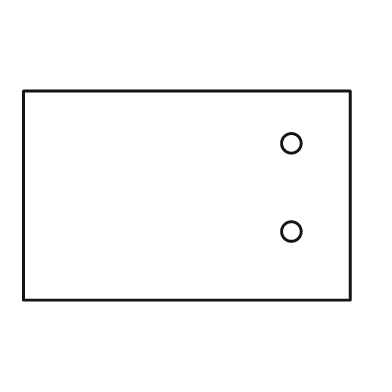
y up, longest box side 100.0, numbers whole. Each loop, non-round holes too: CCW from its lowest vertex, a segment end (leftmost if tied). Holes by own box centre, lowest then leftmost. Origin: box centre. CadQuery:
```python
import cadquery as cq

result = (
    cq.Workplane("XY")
    .moveTo(-50.0, -32.0)
    .lineTo(50.0, -32.0)
    .lineTo(50.0, 32.0)
    .lineTo(-50.0, 32.0)
    .close()
    .moveTo(32.0, -11.0)
    .circle(3.0)
    .moveTo(32.0, 16.0)
    .circle(3.0)
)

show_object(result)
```